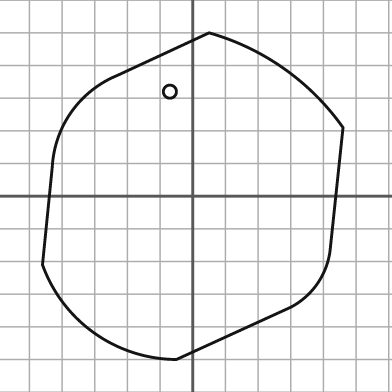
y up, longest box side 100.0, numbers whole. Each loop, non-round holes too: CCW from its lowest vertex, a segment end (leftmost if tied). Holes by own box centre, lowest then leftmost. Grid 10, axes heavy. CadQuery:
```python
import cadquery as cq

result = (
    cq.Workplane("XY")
    .moveTo(-5.0, -50.0)
    .lineTo(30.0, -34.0)
    .threePointArc((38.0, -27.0), (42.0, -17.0))
    .lineTo(46.0, 21.0)
    .threePointArc((28.0, 39.0), (5.0, 50.0))
    .lineTo(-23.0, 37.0)
    .threePointArc((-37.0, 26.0), (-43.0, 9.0))
    .lineTo(-46.0, -21.0)
    .threePointArc((-30.0, -42.0), (-5.0, -50.0))
    .close()
    .moveTo(-7.0, 32.0)
    .circle(2.0)
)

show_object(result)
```